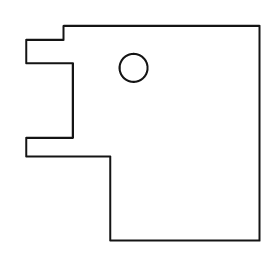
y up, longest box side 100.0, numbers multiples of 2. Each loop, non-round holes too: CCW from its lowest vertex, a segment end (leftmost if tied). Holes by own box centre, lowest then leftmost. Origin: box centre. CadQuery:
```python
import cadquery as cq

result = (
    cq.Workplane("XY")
    .moveTo(-14.0, -46.0)
    .lineTo(50.0, -46.0)
    .lineTo(50.0, 46.0)
    .lineTo(-34.0, 46.0)
    .lineTo(-34.0, 40.0)
    .lineTo(-50.0, 40.0)
    .lineTo(-50.0, 30.0)
    .lineTo(-30.0, 30.0)
    .lineTo(-30.0, -2.0)
    .lineTo(-50.0, -2.0)
    .lineTo(-50.0, -10.0)
    .lineTo(-14.0, -10.0)
    .close()
    .moveTo(-4.0, 28.0)
    .circle(6.0)
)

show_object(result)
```